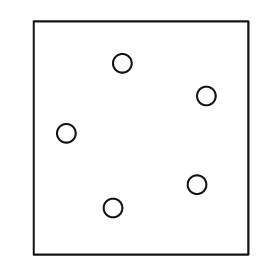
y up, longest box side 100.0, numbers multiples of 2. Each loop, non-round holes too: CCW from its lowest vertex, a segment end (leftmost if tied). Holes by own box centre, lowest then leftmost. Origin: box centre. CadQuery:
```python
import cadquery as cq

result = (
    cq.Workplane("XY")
    .moveTo(-46.0, -50.0)
    .lineTo(46.0, -50.0)
    .lineTo(46.0, 50.0)
    .lineTo(-46.0, 50.0)
    .close()
    .moveTo(-12.0, -30.0)
    .circle(4.0)
    .moveTo(24.0, -20.0)
    .circle(4.0)
    .moveTo(-32.0, 2.0)
    .circle(4.0)
    .moveTo(28.0, 18.0)
    .circle(4.0)
    .moveTo(-8.0, 32.0)
    .circle(4.0)
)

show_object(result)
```